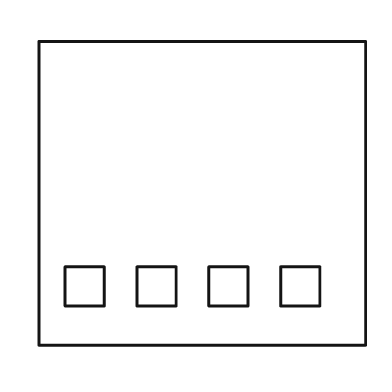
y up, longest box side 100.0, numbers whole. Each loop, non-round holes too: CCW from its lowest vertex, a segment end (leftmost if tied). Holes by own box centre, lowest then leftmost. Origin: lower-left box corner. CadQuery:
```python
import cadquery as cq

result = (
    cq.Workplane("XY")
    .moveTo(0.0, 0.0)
    .lineTo(100.0, 0.0)
    .lineTo(100.0, 93.0)
    .lineTo(0.0, 93.0)
    .close()
    .moveTo(8.0, 12.0)
    .lineTo(20.0, 12.0)
    .lineTo(20.0, 24.0)
    .lineTo(8.0, 24.0)
    .close()
    .moveTo(30.0, 12.0)
    .lineTo(42.0, 12.0)
    .lineTo(42.0, 24.0)
    .lineTo(30.0, 24.0)
    .close()
    .moveTo(52.0, 12.0)
    .lineTo(64.0, 12.0)
    .lineTo(64.0, 24.0)
    .lineTo(52.0, 24.0)
    .close()
    .moveTo(74.0, 12.0)
    .lineTo(86.0, 12.0)
    .lineTo(86.0, 24.0)
    .lineTo(74.0, 24.0)
    .close()
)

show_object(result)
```